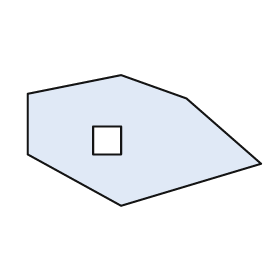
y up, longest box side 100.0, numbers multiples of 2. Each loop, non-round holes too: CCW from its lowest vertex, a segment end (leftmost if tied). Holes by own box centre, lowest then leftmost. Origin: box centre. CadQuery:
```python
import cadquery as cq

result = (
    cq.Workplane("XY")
    .moveTo(-10.0, -28.0)
    .lineTo(50.0, -10.0)
    .lineTo(18.0, 18.0)
    .lineTo(-10.0, 28.0)
    .lineTo(-50.0, 20.0)
    .lineTo(-50.0, -6.0)
    .close()
    .moveTo(-22.0, -6.0)
    .lineTo(-10.0, -6.0)
    .lineTo(-10.0, 6.0)
    .lineTo(-22.0, 6.0)
    .close()
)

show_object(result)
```